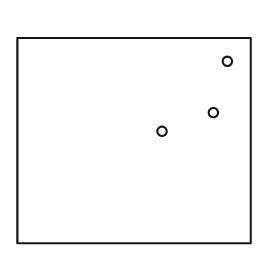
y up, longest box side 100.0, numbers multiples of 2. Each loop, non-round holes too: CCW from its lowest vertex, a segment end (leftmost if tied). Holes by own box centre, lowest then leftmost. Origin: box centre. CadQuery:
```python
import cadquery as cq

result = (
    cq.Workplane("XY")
    .moveTo(-50.0, -44.0)
    .lineTo(50.0, -44.0)
    .lineTo(50.0, 44.0)
    .lineTo(-50.0, 44.0)
    .close()
    .moveTo(12.0, 4.0)
    .circle(2.0)
    .moveTo(34.0, 12.0)
    .circle(2.0)
    .moveTo(40.0, 34.0)
    .circle(2.0)
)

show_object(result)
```